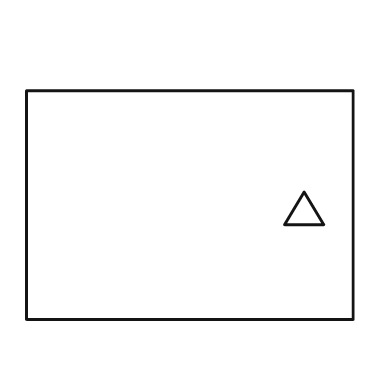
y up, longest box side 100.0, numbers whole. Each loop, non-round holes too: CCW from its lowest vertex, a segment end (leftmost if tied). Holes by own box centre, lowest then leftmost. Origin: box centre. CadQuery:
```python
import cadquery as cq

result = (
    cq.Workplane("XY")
    .moveTo(-50.0, -35.0)
    .lineTo(50.0, -35.0)
    .lineTo(50.0, 35.0)
    .lineTo(-50.0, 35.0)
    .close()
    .moveTo(29.0, -6.0)
    .lineTo(41.0, -6.0)
    .lineTo(35.0, 4.0)
    .close()
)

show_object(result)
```